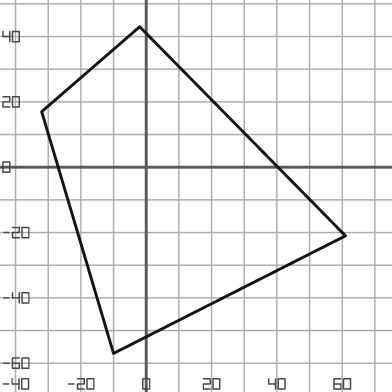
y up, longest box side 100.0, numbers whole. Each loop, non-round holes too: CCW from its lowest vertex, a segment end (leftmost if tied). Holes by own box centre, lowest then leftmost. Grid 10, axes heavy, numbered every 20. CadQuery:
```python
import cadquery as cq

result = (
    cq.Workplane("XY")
    .moveTo(-10.0, -57.0)
    .lineTo(61.0, -21.0)
    .lineTo(-2.0, 43.0)
    .lineTo(-32.0, 17.0)
    .close()
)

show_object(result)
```